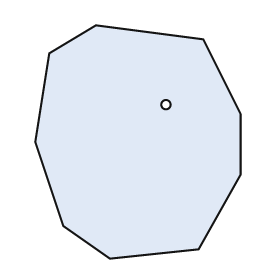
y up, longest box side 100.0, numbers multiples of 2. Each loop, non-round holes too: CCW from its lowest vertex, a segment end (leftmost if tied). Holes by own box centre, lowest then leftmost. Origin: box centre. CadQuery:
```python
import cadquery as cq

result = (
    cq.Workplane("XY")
    .moveTo(-12.0, -50.0)
    .lineTo(26.0, -46.0)
    .lineTo(44.0, -14.0)
    .lineTo(44.0, 12.0)
    .lineTo(28.0, 44.0)
    .lineTo(-18.0, 50.0)
    .lineTo(-38.0, 38.0)
    .lineTo(-44.0, 0.0)
    .lineTo(-32.0, -36.0)
    .close()
    .moveTo(12.0, 16.0)
    .circle(2.0)
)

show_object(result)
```